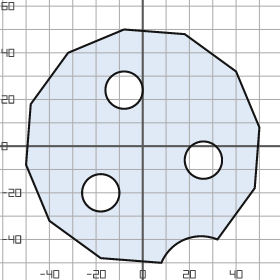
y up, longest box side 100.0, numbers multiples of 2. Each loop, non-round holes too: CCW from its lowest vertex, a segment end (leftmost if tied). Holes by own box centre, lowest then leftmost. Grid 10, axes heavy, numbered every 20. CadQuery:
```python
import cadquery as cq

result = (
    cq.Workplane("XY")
    .moveTo(8.0, -50.0)
    .threePointArc((18.0, -40.0), (32.0, -40.0))
    .lineTo(48.0, -18.0)
    .lineTo(50.0, 8.0)
    .lineTo(40.0, 32.0)
    .lineTo(18.0, 48.0)
    .lineTo(-8.0, 50.0)
    .lineTo(-32.0, 40.0)
    .lineTo(-48.0, 18.0)
    .lineTo(-50.0, -8.0)
    .lineTo(-40.0, -32.0)
    .lineTo(-18.0, -48.0)
    .close()
    .moveTo(-18.0, -20.0)
    .circle(8.0)
    .moveTo(26.0, -6.0)
    .circle(8.0)
    .moveTo(-8.0, 24.0)
    .circle(8.0)
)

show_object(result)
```